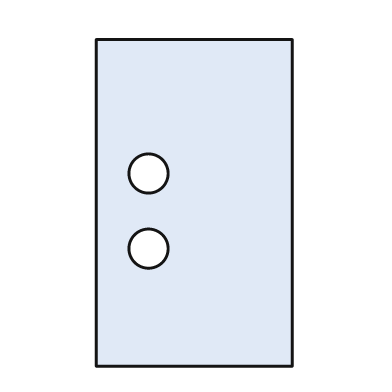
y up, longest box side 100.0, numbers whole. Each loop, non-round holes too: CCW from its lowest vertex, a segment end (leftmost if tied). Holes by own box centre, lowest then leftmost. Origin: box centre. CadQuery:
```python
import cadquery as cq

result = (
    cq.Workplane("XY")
    .moveTo(-30.0, -50.0)
    .lineTo(30.0, -50.0)
    .lineTo(30.0, 50.0)
    .lineTo(-30.0, 50.0)
    .close()
    .moveTo(-14.0, -14.0)
    .circle(6.0)
    .moveTo(-14.0, 9.0)
    .circle(6.0)
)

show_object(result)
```